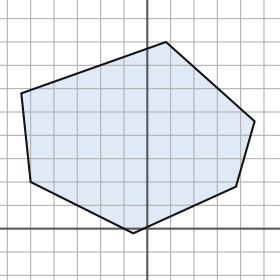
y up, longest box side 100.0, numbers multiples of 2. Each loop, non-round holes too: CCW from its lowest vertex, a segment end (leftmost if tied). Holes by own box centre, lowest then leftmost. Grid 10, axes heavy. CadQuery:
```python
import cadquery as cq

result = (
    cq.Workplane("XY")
    .moveTo(-6.0, -2.0)
    .lineTo(38.0, 18.0)
    .lineTo(46.0, 46.0)
    .lineTo(8.0, 80.0)
    .lineTo(-54.0, 58.0)
    .lineTo(-50.0, 20.0)
    .close()
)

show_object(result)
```